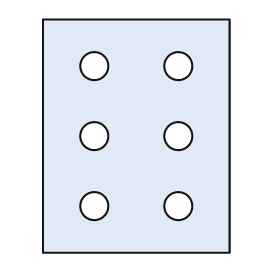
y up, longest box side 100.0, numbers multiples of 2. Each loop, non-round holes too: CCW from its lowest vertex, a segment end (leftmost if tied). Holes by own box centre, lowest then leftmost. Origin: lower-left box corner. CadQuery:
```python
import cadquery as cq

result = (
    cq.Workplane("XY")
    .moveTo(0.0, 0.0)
    .lineTo(80.0, 0.0)
    .lineTo(80.0, 100.0)
    .lineTo(0.0, 100.0)
    .close()
    .moveTo(22.0, 20.0)
    .circle(6.0)
    .moveTo(58.0, 20.0)
    .circle(6.0)
    .moveTo(22.0, 50.0)
    .circle(6.0)
    .moveTo(58.0, 50.0)
    .circle(6.0)
    .moveTo(22.0, 80.0)
    .circle(6.0)
    .moveTo(58.0, 80.0)
    .circle(6.0)
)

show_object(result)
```